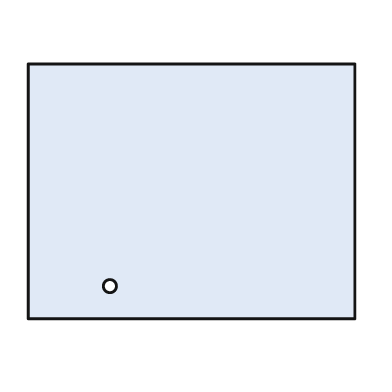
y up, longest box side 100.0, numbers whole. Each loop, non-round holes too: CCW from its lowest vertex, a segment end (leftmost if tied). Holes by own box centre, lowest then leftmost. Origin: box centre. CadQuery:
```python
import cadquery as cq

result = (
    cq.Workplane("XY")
    .moveTo(-50.0, -39.0)
    .lineTo(50.0, -39.0)
    .lineTo(50.0, 39.0)
    .lineTo(-50.0, 39.0)
    .close()
    .moveTo(-25.0, -29.0)
    .circle(2.0)
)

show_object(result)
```